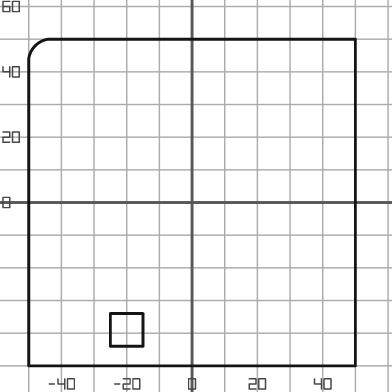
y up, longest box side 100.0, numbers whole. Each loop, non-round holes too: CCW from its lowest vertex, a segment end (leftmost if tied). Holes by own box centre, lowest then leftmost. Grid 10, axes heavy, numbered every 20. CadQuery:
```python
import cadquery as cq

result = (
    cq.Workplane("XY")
    .moveTo(-50.0, -50.0)
    .lineTo(50.0, -50.0)
    .lineTo(50.0, 50.0)
    .lineTo(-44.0, 50.0)
    .threePointArc((-48.0, 48.0), (-50.0, 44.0))
    .close()
    .moveTo(-25.0, -44.0)
    .lineTo(-15.0, -44.0)
    .lineTo(-15.0, -34.0)
    .lineTo(-25.0, -34.0)
    .close()
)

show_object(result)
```